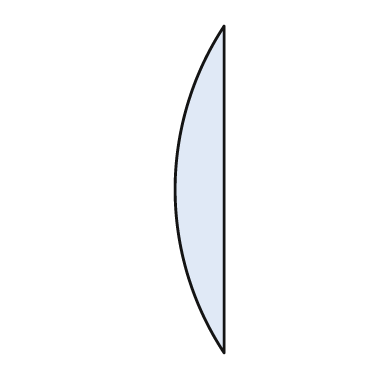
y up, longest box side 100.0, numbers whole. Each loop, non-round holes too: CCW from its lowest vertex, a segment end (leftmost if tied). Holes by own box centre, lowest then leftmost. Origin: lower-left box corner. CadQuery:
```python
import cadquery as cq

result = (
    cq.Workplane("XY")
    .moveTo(15.0, 0.0)
    .lineTo(15.0, 100.0)
    .threePointArc((0.0, 50.0), (15.0, 0.0))
    .close()
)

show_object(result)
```